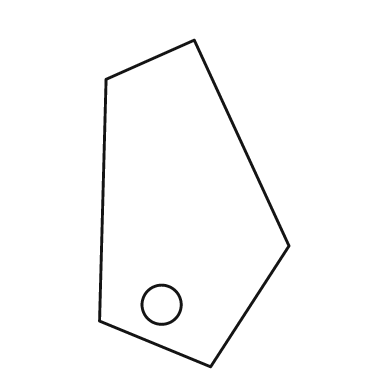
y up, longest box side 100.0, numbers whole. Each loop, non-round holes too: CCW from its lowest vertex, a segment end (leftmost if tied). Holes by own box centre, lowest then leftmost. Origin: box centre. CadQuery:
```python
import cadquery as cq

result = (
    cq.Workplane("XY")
    .moveTo(5.0, -50.0)
    .lineTo(29.0, -13.0)
    .lineTo(0.0, 50.0)
    .lineTo(-27.0, 38.0)
    .lineTo(-29.0, -36.0)
    .close()
    .moveTo(-10.0, -31.0)
    .circle(6.0)
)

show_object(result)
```